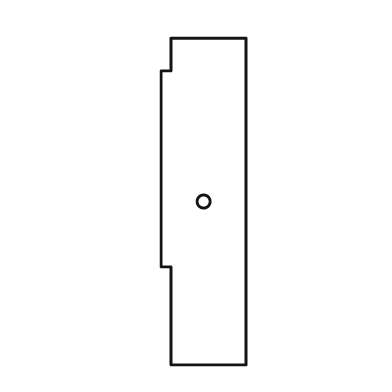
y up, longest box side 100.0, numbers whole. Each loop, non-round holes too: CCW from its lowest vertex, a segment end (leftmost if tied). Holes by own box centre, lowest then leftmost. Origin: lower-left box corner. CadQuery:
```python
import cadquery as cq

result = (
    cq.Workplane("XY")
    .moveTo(3.0, 0.0)
    .lineTo(26.0, 0.0)
    .lineTo(26.0, 100.0)
    .lineTo(3.0, 100.0)
    .lineTo(3.0, 90.0)
    .lineTo(0.0, 90.0)
    .lineTo(0.0, 30.0)
    .lineTo(3.0, 30.0)
    .close()
    .moveTo(13.0, 50.0)
    .circle(2.0)
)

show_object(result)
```